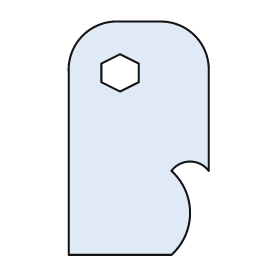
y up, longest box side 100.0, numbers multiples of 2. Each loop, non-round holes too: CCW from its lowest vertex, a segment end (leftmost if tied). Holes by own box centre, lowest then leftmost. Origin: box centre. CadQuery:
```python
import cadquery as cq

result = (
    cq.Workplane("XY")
    .moveTo(-30.0, -50.0)
    .lineTo(14.0, -50.0)
    .threePointArc((22.0, -32.0), (14.0, -14.0))
    .threePointArc((22.0, -10.0), (30.0, -14.0))
    .lineTo(30.0, 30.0)
    .threePointArc((24.0, 44.0), (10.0, 50.0))
    .lineTo(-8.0, 50.0)
    .threePointArc((-24.0, 44.0), (-30.0, 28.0))
    .close()
    .moveTo(-8.0, 20.0)
    .lineTo(0.0, 24.0)
    .lineTo(0.0, 32.0)
    .lineTo(-8.0, 36.0)
    .lineTo(-16.0, 32.0)
    .lineTo(-16.0, 24.0)
    .close()
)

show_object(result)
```